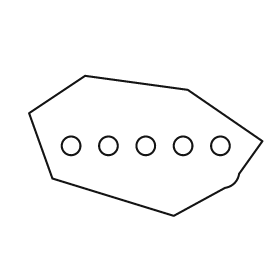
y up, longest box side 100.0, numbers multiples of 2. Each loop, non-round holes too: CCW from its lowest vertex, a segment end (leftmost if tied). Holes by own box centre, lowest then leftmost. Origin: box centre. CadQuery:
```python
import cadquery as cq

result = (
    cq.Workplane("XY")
    .moveTo(12.0, -30.0)
    .lineTo(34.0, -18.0)
    .threePointArc((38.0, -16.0), (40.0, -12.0))
    .lineTo(50.0, 2.0)
    .lineTo(18.0, 24.0)
    .lineTo(-26.0, 30.0)
    .lineTo(-50.0, 14.0)
    .lineTo(-40.0, -14.0)
    .close()
    .moveTo(-32.0, 0.0)
    .circle(4.0)
    .moveTo(-16.0, 0.0)
    .circle(4.0)
    .moveTo(0.0, 0.0)
    .circle(4.0)
    .moveTo(16.0, 0.0)
    .circle(4.0)
    .moveTo(32.0, 0.0)
    .circle(4.0)
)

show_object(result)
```